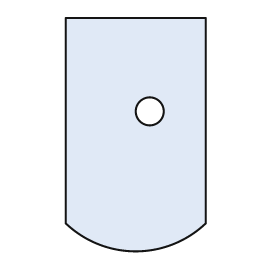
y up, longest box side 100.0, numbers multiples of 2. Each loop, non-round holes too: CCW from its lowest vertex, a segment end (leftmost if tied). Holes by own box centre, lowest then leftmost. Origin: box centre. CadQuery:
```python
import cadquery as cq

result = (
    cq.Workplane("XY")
    .moveTo(-30.0, -38.0)
    .threePointArc((0.0, -50.0), (30.0, -38.0))
    .lineTo(30.0, 50.0)
    .lineTo(-30.0, 50.0)
    .close()
    .moveTo(6.0, 10.0)
    .circle(6.0)
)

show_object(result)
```